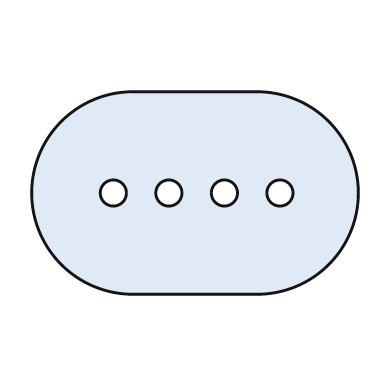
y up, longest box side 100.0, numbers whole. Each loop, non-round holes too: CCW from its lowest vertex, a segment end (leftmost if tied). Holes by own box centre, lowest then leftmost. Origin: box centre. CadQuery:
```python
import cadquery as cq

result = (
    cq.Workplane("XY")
    .moveTo(-19.0, -31.0)
    .lineTo(19.0, -31.0)
    .threePointArc((50.0, 0.0), (19.0, 31.0))
    .lineTo(-19.0, 31.0)
    .threePointArc((-50.0, 0.0), (-19.0, -31.0))
    .close()
    .moveTo(-25.0, 0.0)
    .circle(4.0)
    .moveTo(-8.0, 0.0)
    .circle(4.0)
    .moveTo(9.0, 0.0)
    .circle(4.0)
    .moveTo(26.0, 0.0)
    .circle(4.0)
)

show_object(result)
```